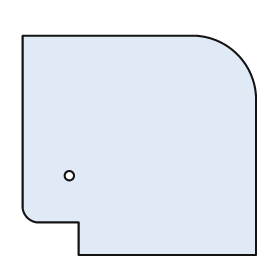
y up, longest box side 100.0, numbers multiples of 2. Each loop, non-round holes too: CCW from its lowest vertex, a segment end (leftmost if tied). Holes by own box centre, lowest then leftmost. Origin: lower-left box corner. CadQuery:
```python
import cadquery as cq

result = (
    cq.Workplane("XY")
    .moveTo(24.0, 0.0)
    .lineTo(100.0, 0.0)
    .lineTo(100.0, 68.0)
    .threePointArc((92.0, 86.0), (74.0, 94.0))
    .lineTo(0.0, 94.0)
    .lineTo(0.0, 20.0)
    .threePointArc((2.0, 16.0), (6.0, 14.0))
    .lineTo(24.0, 14.0)
    .close()
    .moveTo(20.0, 34.0)
    .circle(2.0)
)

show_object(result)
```